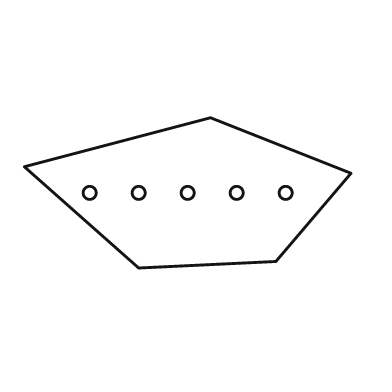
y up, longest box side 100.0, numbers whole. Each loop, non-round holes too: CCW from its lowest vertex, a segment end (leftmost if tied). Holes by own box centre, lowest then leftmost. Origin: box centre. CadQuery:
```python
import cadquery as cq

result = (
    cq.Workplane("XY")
    .moveTo(-15.0, -23.0)
    .lineTo(27.0, -21.0)
    .lineTo(50.0, 6.0)
    .lineTo(7.0, 23.0)
    .lineTo(-50.0, 8.0)
    .close()
    .moveTo(-30.0, 0.0)
    .circle(2.0)
    .moveTo(-15.0, 0.0)
    .circle(2.0)
    .moveTo(0.0, 0.0)
    .circle(2.0)
    .moveTo(15.0, 0.0)
    .circle(2.0)
    .moveTo(30.0, 0.0)
    .circle(2.0)
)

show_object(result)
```